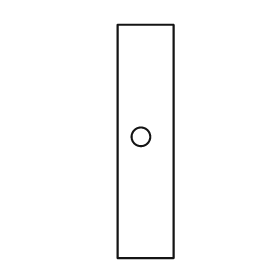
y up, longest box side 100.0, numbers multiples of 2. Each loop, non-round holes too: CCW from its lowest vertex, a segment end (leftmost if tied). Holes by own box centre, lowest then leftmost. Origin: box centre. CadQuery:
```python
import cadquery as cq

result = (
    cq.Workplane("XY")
    .moveTo(-12.0, -50.0)
    .lineTo(12.0, -50.0)
    .lineTo(12.0, 50.0)
    .lineTo(-12.0, 50.0)
    .close()
    .moveTo(-2.0, 2.0)
    .circle(4.0)
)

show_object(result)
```